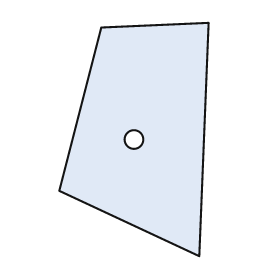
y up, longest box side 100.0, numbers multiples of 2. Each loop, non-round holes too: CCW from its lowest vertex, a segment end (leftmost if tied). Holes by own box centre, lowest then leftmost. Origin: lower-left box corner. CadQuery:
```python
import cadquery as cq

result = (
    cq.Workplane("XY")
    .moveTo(60.0, 0.0)
    .lineTo(64.0, 100.0)
    .lineTo(18.0, 98.0)
    .lineTo(0.0, 28.0)
    .close()
    .moveTo(32.0, 50.0)
    .circle(4.0)
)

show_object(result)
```